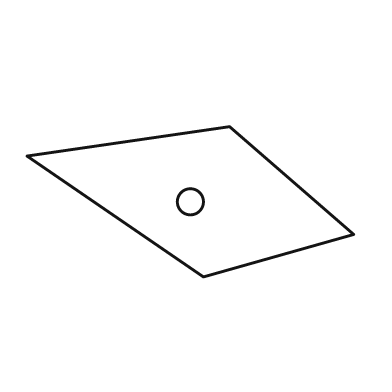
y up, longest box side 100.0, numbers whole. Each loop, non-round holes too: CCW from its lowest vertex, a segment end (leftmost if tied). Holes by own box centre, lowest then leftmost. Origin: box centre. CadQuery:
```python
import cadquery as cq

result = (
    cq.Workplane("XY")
    .moveTo(4.0, -23.0)
    .lineTo(50.0, -10.0)
    .lineTo(12.0, 23.0)
    .lineTo(-50.0, 14.0)
    .close()
    .moveTo(0.0, 0.0)
    .circle(4.0)
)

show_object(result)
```